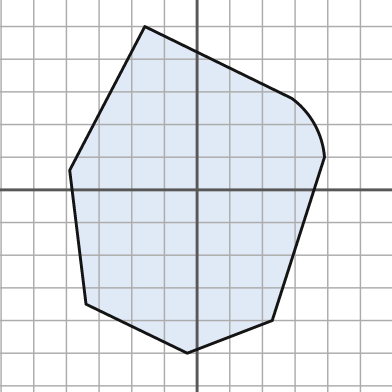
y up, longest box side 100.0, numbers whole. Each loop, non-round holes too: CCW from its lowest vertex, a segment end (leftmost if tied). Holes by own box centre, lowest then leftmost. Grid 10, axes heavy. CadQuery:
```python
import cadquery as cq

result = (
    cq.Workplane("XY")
    .moveTo(-3.0, -50.0)
    .lineTo(23.0, -40.0)
    .lineTo(39.0, 10.0)
    .threePointArc((36.0, 20.0), (29.0, 28.0))
    .lineTo(-16.0, 50.0)
    .lineTo(-39.0, 6.0)
    .lineTo(-34.0, -35.0)
    .close()
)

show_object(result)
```